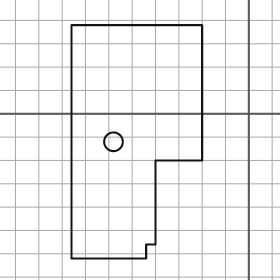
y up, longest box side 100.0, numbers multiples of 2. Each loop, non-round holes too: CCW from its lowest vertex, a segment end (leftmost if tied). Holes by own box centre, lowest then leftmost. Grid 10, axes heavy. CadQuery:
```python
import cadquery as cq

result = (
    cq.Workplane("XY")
    .moveTo(-76.0, -62.0)
    .lineTo(-44.0, -62.0)
    .lineTo(-44.0, -56.0)
    .lineTo(-40.0, -56.0)
    .lineTo(-40.0, -20.0)
    .lineTo(-20.0, -20.0)
    .lineTo(-20.0, 38.0)
    .lineTo(-76.0, 38.0)
    .close()
    .moveTo(-58.0, -12.0)
    .circle(4.0)
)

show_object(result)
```